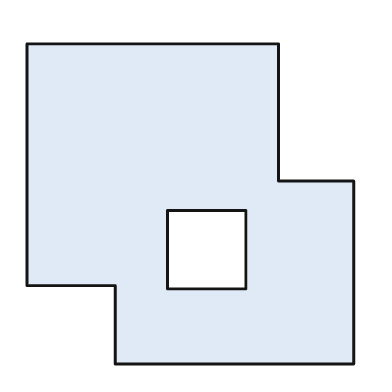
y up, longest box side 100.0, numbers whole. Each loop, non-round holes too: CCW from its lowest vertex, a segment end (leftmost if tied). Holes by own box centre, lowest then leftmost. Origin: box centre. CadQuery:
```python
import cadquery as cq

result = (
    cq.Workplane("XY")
    .moveTo(-23.0, -49.0)
    .lineTo(50.0, -49.0)
    .lineTo(50.0, 7.0)
    .lineTo(27.0, 7.0)
    .lineTo(27.0, 49.0)
    .lineTo(-50.0, 49.0)
    .lineTo(-50.0, -25.0)
    .lineTo(-23.0, -25.0)
    .close()
    .moveTo(-7.0, -26.0)
    .lineTo(17.0, -26.0)
    .lineTo(17.0, -2.0)
    .lineTo(-7.0, -2.0)
    .close()
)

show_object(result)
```